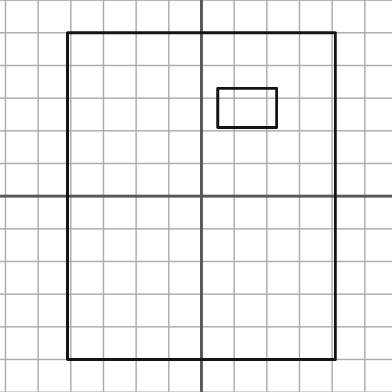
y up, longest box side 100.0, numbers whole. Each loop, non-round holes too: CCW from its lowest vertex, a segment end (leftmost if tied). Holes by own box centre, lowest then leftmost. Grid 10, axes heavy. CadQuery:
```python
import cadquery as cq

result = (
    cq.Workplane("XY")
    .moveTo(-41.0, -50.0)
    .lineTo(41.0, -50.0)
    .lineTo(41.0, 50.0)
    .lineTo(-41.0, 50.0)
    .close()
    .moveTo(5.0, 21.0)
    .lineTo(23.0, 21.0)
    .lineTo(23.0, 33.0)
    .lineTo(5.0, 33.0)
    .close()
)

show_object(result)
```